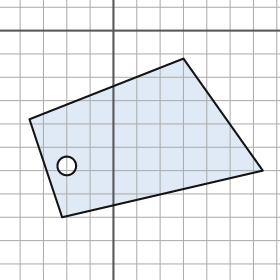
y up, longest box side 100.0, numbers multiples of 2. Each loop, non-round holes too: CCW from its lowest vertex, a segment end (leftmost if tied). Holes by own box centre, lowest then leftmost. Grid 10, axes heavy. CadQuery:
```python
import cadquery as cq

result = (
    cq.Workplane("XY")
    .moveTo(-22.0, -80.0)
    .lineTo(64.0, -60.0)
    .lineTo(30.0, -12.0)
    .lineTo(-36.0, -38.0)
    .close()
    .moveTo(-20.0, -58.0)
    .circle(4.0)
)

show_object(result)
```